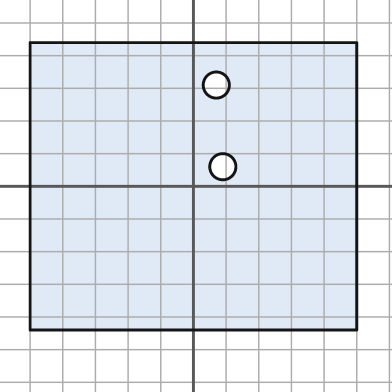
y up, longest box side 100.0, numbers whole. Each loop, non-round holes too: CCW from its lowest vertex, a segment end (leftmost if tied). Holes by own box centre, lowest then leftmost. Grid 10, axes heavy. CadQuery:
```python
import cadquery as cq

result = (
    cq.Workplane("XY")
    .moveTo(-50.0, -44.0)
    .lineTo(50.0, -44.0)
    .lineTo(50.0, 44.0)
    .lineTo(-50.0, 44.0)
    .close()
    .moveTo(9.0, 6.0)
    .circle(4.0)
    .moveTo(7.0, 31.0)
    .circle(4.0)
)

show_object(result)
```